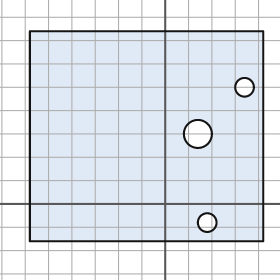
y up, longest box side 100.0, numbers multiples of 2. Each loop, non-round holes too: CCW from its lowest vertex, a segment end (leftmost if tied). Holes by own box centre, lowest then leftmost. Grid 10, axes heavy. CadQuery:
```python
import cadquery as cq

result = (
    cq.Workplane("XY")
    .moveTo(-58.0, -16.0)
    .lineTo(42.0, -16.0)
    .lineTo(42.0, 74.0)
    .lineTo(-58.0, 74.0)
    .close()
    .moveTo(18.0, -8.0)
    .circle(4.0)
    .moveTo(14.0, 30.0)
    .circle(6.0)
    .moveTo(34.0, 50.0)
    .circle(4.0)
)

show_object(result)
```